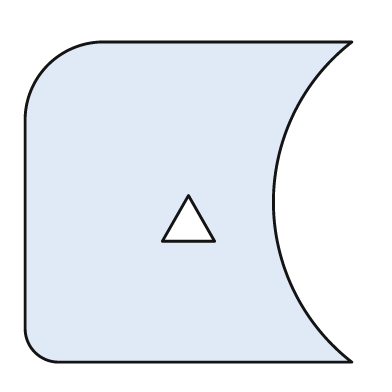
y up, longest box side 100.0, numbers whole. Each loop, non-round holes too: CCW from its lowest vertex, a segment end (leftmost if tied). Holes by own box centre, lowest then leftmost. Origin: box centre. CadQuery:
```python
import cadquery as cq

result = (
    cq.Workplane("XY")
    .moveTo(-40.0, -49.0)
    .lineTo(50.0, -49.0)
    .threePointArc((26.0, 0.0), (50.0, 49.0))
    .lineTo(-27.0, 49.0)
    .threePointArc((-43.0, 42.0), (-50.0, 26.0))
    .lineTo(-50.0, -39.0)
    .threePointArc((-47.0, -46.0), (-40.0, -49.0))
    .close()
    .moveTo(-8.0, -12.0)
    .lineTo(8.0, -12.0)
    .lineTo(0.0, 2.0)
    .close()
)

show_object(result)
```